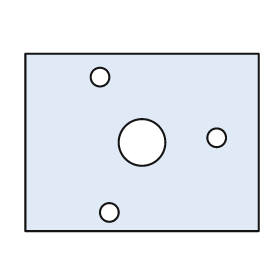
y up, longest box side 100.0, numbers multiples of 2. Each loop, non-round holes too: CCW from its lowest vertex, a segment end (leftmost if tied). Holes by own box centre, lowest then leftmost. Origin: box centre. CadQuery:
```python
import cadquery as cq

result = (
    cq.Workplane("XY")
    .moveTo(-50.0, -38.0)
    .lineTo(50.0, -38.0)
    .lineTo(50.0, 38.0)
    .lineTo(-50.0, 38.0)
    .close()
    .moveTo(-14.0, -30.0)
    .circle(4.0)
    .moveTo(0.0, 0.0)
    .circle(10.0)
    .moveTo(32.0, 2.0)
    .circle(4.0)
    .moveTo(-18.0, 28.0)
    .circle(4.0)
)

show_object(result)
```